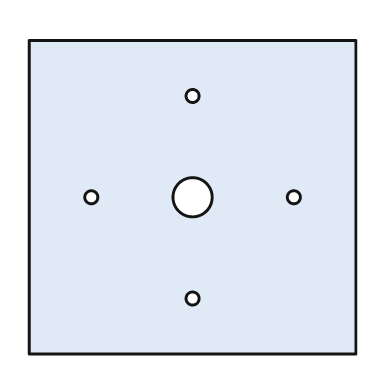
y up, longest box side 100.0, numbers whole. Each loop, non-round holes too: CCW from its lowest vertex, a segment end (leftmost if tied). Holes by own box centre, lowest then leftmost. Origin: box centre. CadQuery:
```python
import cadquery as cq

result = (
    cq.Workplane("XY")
    .moveTo(-50.0, -48.0)
    .lineTo(50.0, -48.0)
    .lineTo(50.0, 48.0)
    .lineTo(-50.0, 48.0)
    .close()
    .moveTo(0.0, -31.0)
    .circle(2.0)
    .moveTo(-31.0, 0.0)
    .circle(2.0)
    .moveTo(0.0, 0.0)
    .circle(6.0)
    .moveTo(31.0, 0.0)
    .circle(2.0)
    .moveTo(0.0, 31.0)
    .circle(2.0)
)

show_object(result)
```